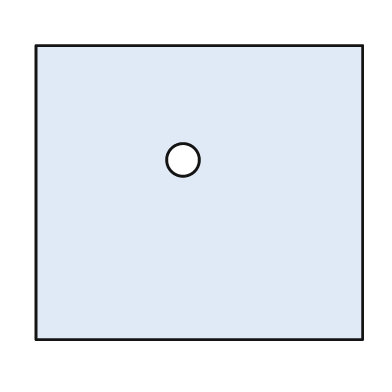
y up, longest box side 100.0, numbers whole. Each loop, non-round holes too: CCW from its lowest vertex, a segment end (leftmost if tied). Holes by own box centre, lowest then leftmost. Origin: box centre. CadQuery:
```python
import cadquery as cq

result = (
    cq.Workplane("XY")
    .moveTo(-50.0, -45.0)
    .lineTo(50.0, -45.0)
    .lineTo(50.0, 45.0)
    .lineTo(-50.0, 45.0)
    .close()
    .moveTo(-5.0, 10.0)
    .circle(5.0)
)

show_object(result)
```